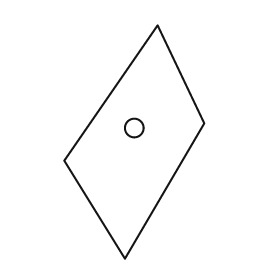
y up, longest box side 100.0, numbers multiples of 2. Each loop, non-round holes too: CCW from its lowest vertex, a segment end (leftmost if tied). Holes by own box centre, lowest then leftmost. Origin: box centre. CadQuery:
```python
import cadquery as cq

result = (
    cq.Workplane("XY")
    .moveTo(-4.0, -50.0)
    .lineTo(30.0, 8.0)
    .lineTo(10.0, 50.0)
    .lineTo(-30.0, -8.0)
    .close()
    .moveTo(0.0, 6.0)
    .circle(4.0)
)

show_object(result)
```